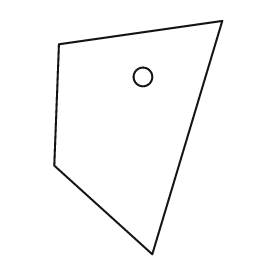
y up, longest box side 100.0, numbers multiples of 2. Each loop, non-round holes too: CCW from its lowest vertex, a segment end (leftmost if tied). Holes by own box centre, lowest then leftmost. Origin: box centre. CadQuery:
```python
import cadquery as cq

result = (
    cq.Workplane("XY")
    .moveTo(6.0, -50.0)
    .lineTo(36.0, 50.0)
    .lineTo(-34.0, 40.0)
    .lineTo(-36.0, -12.0)
    .close()
    .moveTo(2.0, 26.0)
    .circle(4.0)
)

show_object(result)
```